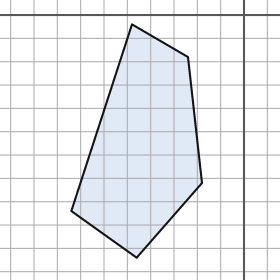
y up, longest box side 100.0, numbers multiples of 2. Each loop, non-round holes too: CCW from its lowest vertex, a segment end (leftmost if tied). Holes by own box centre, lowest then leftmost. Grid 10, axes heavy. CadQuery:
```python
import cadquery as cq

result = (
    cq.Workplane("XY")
    .moveTo(-46.0, -104.0)
    .lineTo(-18.0, -72.0)
    .lineTo(-24.0, -18.0)
    .lineTo(-48.0, -4.0)
    .lineTo(-74.0, -84.0)
    .close()
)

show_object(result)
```